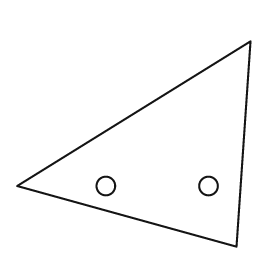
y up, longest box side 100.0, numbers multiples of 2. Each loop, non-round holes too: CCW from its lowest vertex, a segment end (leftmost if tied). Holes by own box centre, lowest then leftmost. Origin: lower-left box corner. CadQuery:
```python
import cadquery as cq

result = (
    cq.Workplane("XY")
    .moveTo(94.0, 0.0)
    .lineTo(100.0, 88.0)
    .lineTo(0.0, 26.0)
    .close()
    .moveTo(38.0, 26.0)
    .circle(4.0)
    .moveTo(82.0, 26.0)
    .circle(4.0)
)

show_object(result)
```